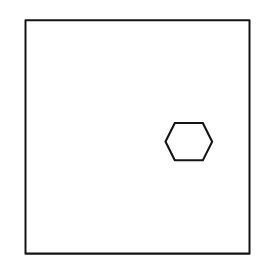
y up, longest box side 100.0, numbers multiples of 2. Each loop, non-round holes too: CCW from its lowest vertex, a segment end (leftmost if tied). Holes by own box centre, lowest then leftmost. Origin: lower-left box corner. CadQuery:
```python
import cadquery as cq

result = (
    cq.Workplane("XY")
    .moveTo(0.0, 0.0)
    .lineTo(96.0, 0.0)
    .lineTo(96.0, 100.0)
    .lineTo(0.0, 100.0)
    .close()
    .moveTo(64.0, 40.0)
    .lineTo(76.0, 40.0)
    .lineTo(80.0, 48.0)
    .lineTo(76.0, 56.0)
    .lineTo(64.0, 56.0)
    .lineTo(60.0, 48.0)
    .close()
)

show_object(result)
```